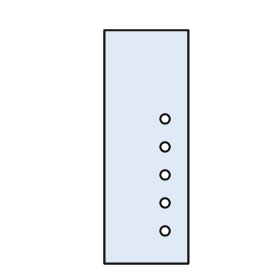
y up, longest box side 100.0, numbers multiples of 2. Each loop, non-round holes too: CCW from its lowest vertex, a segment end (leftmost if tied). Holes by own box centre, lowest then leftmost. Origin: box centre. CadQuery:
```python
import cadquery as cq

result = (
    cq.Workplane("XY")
    .moveTo(-18.0, -50.0)
    .lineTo(18.0, -50.0)
    .lineTo(18.0, 50.0)
    .lineTo(-18.0, 50.0)
    .close()
    .moveTo(8.0, -36.0)
    .circle(2.0)
    .moveTo(8.0, -24.0)
    .circle(2.0)
    .moveTo(8.0, -12.0)
    .circle(2.0)
    .moveTo(8.0, 0.0)
    .circle(2.0)
    .moveTo(8.0, 12.0)
    .circle(2.0)
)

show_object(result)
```